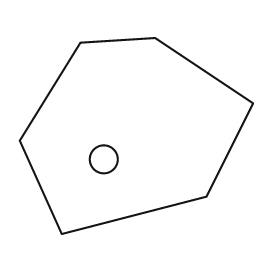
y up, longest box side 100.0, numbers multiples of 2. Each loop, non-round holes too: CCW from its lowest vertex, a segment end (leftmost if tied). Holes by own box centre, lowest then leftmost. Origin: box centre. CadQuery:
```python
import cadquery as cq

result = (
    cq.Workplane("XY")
    .moveTo(-32.0, -42.0)
    .lineTo(30.0, -26.0)
    .lineTo(50.0, 14.0)
    .lineTo(8.0, 42.0)
    .lineTo(-24.0, 40.0)
    .lineTo(-50.0, -2.0)
    .close()
    .moveTo(-14.0, -10.0)
    .circle(6.0)
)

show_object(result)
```